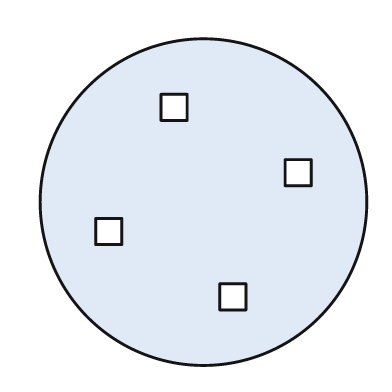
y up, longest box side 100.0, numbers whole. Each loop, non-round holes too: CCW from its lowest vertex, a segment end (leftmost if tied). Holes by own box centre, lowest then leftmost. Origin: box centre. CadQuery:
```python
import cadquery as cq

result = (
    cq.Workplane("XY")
    .moveTo(0.0, 0.0)
    .circle(50.0)
    .moveTo(5.0, -33.0)
    .lineTo(13.0, -33.0)
    .lineTo(13.0, -25.0)
    .lineTo(5.0, -25.0)
    .close()
    .moveTo(-33.0, -13.0)
    .lineTo(-25.0, -13.0)
    .lineTo(-25.0, -5.0)
    .lineTo(-33.0, -5.0)
    .close()
    .moveTo(25.0, 5.0)
    .lineTo(33.0, 5.0)
    .lineTo(33.0, 13.0)
    .lineTo(25.0, 13.0)
    .close()
    .moveTo(-13.0, 25.0)
    .lineTo(-5.0, 25.0)
    .lineTo(-5.0, 33.0)
    .lineTo(-13.0, 33.0)
    .close()
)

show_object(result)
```